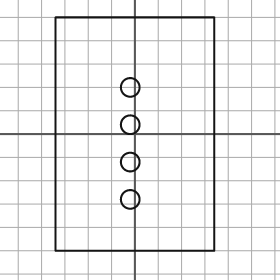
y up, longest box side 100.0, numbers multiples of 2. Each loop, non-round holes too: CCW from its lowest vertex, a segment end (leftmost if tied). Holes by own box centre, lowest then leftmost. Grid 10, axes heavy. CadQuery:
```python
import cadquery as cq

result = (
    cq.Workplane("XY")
    .moveTo(-34.0, -50.0)
    .lineTo(34.0, -50.0)
    .lineTo(34.0, 50.0)
    .lineTo(-34.0, 50.0)
    .close()
    .moveTo(-2.0, -28.0)
    .circle(4.0)
    .moveTo(-2.0, -12.0)
    .circle(4.0)
    .moveTo(-2.0, 4.0)
    .circle(4.0)
    .moveTo(-2.0, 20.0)
    .circle(4.0)
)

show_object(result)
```